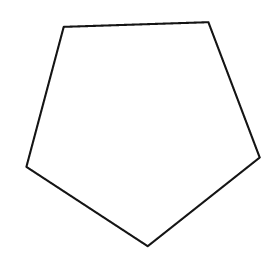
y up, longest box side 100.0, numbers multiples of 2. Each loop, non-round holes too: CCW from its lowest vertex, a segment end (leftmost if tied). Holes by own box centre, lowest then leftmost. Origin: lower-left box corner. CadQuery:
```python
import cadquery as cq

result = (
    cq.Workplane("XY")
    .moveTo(52.0, 0.0)
    .lineTo(100.0, 38.0)
    .lineTo(78.0, 96.0)
    .lineTo(16.0, 94.0)
    .lineTo(0.0, 34.0)
    .close()
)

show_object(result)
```